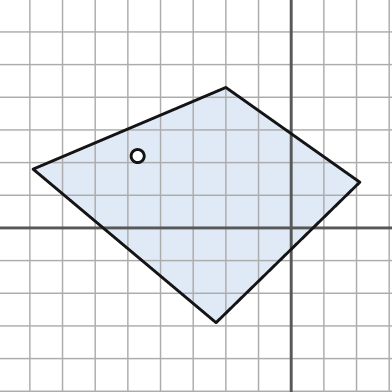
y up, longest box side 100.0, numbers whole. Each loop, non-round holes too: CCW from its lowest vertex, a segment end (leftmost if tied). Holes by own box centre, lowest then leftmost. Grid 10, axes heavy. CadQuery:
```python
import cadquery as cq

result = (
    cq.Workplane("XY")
    .moveTo(-23.0, -29.0)
    .lineTo(21.0, 14.0)
    .lineTo(-20.0, 43.0)
    .lineTo(-79.0, 18.0)
    .close()
    .moveTo(-47.0, 22.0)
    .circle(2.0)
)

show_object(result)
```